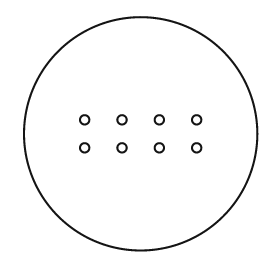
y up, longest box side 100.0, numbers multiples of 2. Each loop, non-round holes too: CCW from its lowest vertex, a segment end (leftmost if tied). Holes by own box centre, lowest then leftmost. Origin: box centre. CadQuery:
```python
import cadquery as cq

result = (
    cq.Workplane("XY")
    .moveTo(0.0, 0.0)
    .circle(50.0)
    .moveTo(-24.0, -6.0)
    .circle(2.0)
    .moveTo(-8.0, -6.0)
    .circle(2.0)
    .moveTo(8.0, -6.0)
    .circle(2.0)
    .moveTo(24.0, -6.0)
    .circle(2.0)
    .moveTo(-24.0, 6.0)
    .circle(2.0)
    .moveTo(-8.0, 6.0)
    .circle(2.0)
    .moveTo(8.0, 6.0)
    .circle(2.0)
    .moveTo(24.0, 6.0)
    .circle(2.0)
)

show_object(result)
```